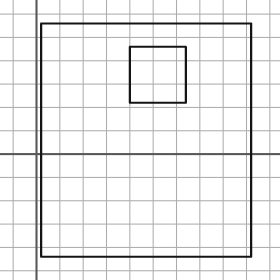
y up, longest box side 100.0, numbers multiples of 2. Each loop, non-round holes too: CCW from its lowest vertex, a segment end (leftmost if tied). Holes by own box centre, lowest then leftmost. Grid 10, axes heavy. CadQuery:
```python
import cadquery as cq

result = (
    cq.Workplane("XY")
    .moveTo(2.0, -44.0)
    .lineTo(92.0, -44.0)
    .lineTo(92.0, 56.0)
    .lineTo(2.0, 56.0)
    .close()
    .moveTo(40.0, 22.0)
    .lineTo(64.0, 22.0)
    .lineTo(64.0, 46.0)
    .lineTo(40.0, 46.0)
    .close()
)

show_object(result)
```